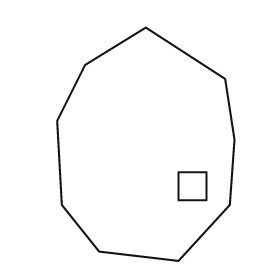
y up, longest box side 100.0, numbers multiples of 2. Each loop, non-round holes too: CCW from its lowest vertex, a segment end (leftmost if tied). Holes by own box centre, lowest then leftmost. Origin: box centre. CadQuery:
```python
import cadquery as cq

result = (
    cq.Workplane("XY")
    .moveTo(14.0, -50.0)
    .lineTo(36.0, -26.0)
    .lineTo(38.0, 2.0)
    .lineTo(34.0, 28.0)
    .lineTo(0.0, 50.0)
    .lineTo(-26.0, 34.0)
    .lineTo(-38.0, 10.0)
    .lineTo(-36.0, -26.0)
    .lineTo(-20.0, -46.0)
    .close()
    .moveTo(14.0, -24.0)
    .lineTo(26.0, -24.0)
    .lineTo(26.0, -12.0)
    .lineTo(14.0, -12.0)
    .close()
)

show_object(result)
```